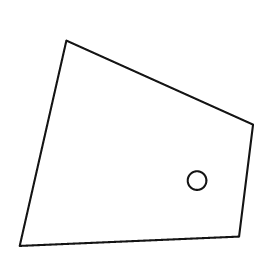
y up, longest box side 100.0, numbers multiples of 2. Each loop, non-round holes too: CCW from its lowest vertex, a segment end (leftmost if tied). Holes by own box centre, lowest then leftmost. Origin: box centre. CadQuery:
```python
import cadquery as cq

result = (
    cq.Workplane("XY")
    .moveTo(-50.0, -44.0)
    .lineTo(44.0, -40.0)
    .lineTo(50.0, 8.0)
    .lineTo(-30.0, 44.0)
    .close()
    .moveTo(26.0, -16.0)
    .circle(4.0)
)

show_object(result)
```